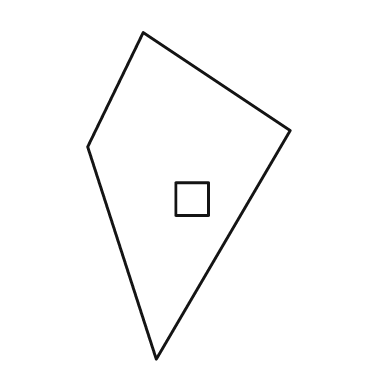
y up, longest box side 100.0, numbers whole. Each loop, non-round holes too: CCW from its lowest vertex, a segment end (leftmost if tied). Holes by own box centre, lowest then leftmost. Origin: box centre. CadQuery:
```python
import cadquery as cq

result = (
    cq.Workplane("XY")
    .moveTo(-10.0, -50.0)
    .lineTo(31.0, 20.0)
    .lineTo(-14.0, 50.0)
    .lineTo(-31.0, 15.0)
    .close()
    .moveTo(-4.0, -6.0)
    .lineTo(6.0, -6.0)
    .lineTo(6.0, 4.0)
    .lineTo(-4.0, 4.0)
    .close()
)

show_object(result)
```